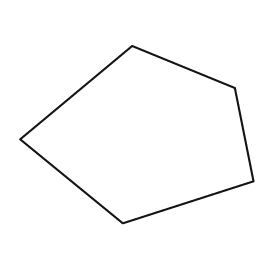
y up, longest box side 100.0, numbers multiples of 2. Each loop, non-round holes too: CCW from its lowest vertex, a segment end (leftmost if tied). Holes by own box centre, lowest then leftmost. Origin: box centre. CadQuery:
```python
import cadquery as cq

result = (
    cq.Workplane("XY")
    .moveTo(-6.0, -38.0)
    .lineTo(50.0, -20.0)
    .lineTo(42.0, 20.0)
    .lineTo(-2.0, 38.0)
    .lineTo(-50.0, -2.0)
    .close()
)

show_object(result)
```